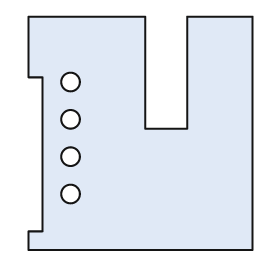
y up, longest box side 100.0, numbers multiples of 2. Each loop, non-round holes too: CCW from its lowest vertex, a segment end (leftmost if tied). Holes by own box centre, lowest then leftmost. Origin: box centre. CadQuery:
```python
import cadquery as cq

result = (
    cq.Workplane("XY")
    .moveTo(-48.0, -50.0)
    .lineTo(48.0, -50.0)
    .lineTo(48.0, 50.0)
    .lineTo(20.0, 50.0)
    .lineTo(20.0, 2.0)
    .lineTo(2.0, 2.0)
    .lineTo(2.0, 50.0)
    .lineTo(-48.0, 50.0)
    .lineTo(-48.0, 24.0)
    .lineTo(-42.0, 24.0)
    .lineTo(-42.0, -42.0)
    .lineTo(-48.0, -42.0)
    .close()
    .moveTo(-30.0, -26.0)
    .circle(4.0)
    .moveTo(-30.0, -10.0)
    .circle(4.0)
    .moveTo(-30.0, 6.0)
    .circle(4.0)
    .moveTo(-30.0, 22.0)
    .circle(4.0)
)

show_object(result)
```